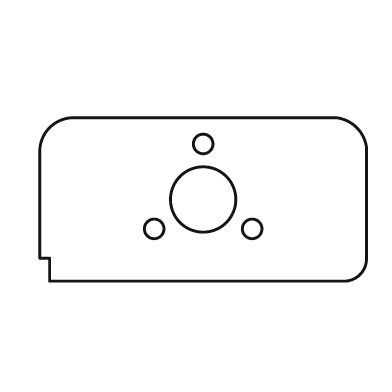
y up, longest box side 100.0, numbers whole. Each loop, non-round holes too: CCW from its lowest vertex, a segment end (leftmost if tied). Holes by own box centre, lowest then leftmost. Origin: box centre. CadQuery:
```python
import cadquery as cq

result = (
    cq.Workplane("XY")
    .moveTo(-47.0, -25.0)
    .lineTo(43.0, -25.0)
    .threePointArc((48.0, -23.0), (50.0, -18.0))
    .lineTo(50.0, 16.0)
    .threePointArc((47.0, 22.0), (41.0, 25.0))
    .lineTo(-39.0, 25.0)
    .threePointArc((-47.0, 22.0), (-50.0, 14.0))
    .lineTo(-50.0, -18.0)
    .lineTo(-47.0, -18.0)
    .close()
    .moveTo(-15.0, -9.0)
    .circle(3.0)
    .moveTo(15.0, -9.0)
    .circle(3.0)
    .moveTo(0.0, 0.0)
    .circle(10.0)
    .moveTo(0.0, 17.0)
    .circle(3.0)
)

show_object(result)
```